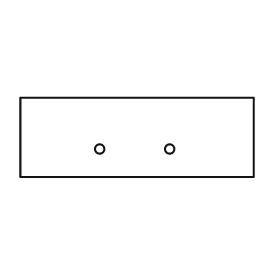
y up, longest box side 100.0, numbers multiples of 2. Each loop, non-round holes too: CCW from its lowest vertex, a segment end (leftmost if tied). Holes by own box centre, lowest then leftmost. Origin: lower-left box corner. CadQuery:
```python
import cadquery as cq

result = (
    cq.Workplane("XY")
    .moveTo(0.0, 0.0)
    .lineTo(100.0, 0.0)
    .lineTo(100.0, 34.0)
    .lineTo(0.0, 34.0)
    .close()
    .moveTo(34.0, 12.0)
    .circle(2.0)
    .moveTo(64.0, 12.0)
    .circle(2.0)
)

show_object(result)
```